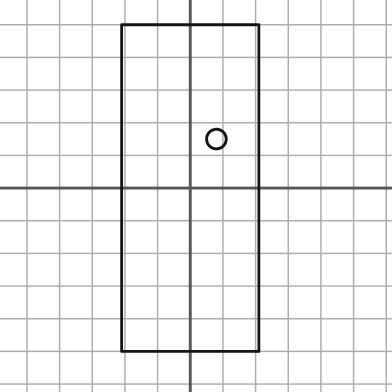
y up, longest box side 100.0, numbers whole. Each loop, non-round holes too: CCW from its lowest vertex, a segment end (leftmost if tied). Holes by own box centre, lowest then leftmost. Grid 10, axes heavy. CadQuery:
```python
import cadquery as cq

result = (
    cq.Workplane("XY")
    .moveTo(-21.0, -50.0)
    .lineTo(21.0, -50.0)
    .lineTo(21.0, 50.0)
    .lineTo(-21.0, 50.0)
    .close()
    .moveTo(8.0, 15.0)
    .circle(3.0)
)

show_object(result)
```